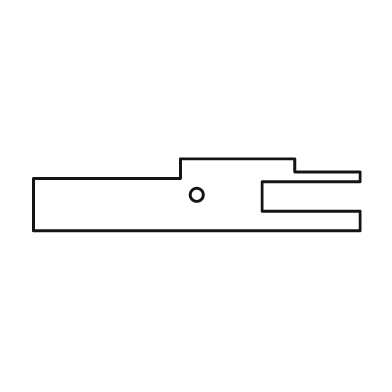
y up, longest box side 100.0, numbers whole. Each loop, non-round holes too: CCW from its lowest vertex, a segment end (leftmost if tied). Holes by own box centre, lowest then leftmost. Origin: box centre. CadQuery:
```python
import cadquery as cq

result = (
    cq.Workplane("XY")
    .moveTo(-50.0, -11.0)
    .lineTo(50.0, -11.0)
    .lineTo(50.0, -5.0)
    .lineTo(20.0, -5.0)
    .lineTo(20.0, 4.0)
    .lineTo(50.0, 4.0)
    .lineTo(50.0, 7.0)
    .lineTo(30.0, 7.0)
    .lineTo(30.0, 11.0)
    .lineTo(-5.0, 11.0)
    .lineTo(-5.0, 5.0)
    .lineTo(-50.0, 5.0)
    .close()
    .moveTo(0.0, 0.0)
    .circle(2.0)
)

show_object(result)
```